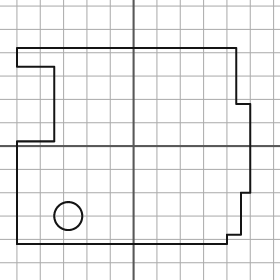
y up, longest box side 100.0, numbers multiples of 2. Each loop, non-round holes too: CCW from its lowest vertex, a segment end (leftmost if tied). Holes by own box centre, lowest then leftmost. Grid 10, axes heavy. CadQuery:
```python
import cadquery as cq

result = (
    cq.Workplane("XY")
    .moveTo(-50.0, -42.0)
    .lineTo(40.0, -42.0)
    .lineTo(40.0, -38.0)
    .lineTo(46.0, -38.0)
    .lineTo(46.0, -20.0)
    .lineTo(50.0, -20.0)
    .lineTo(50.0, 18.0)
    .lineTo(44.0, 18.0)
    .lineTo(44.0, 42.0)
    .lineTo(-50.0, 42.0)
    .lineTo(-50.0, 34.0)
    .lineTo(-34.0, 34.0)
    .lineTo(-34.0, 2.0)
    .lineTo(-50.0, 2.0)
    .close()
    .moveTo(-28.0, -30.0)
    .circle(6.0)
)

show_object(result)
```